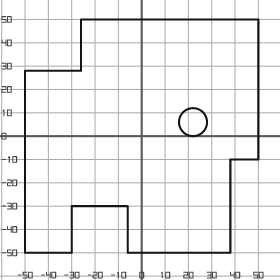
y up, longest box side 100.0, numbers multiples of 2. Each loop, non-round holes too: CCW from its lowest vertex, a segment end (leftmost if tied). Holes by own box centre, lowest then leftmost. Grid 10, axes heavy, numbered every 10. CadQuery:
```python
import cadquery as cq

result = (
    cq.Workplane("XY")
    .moveTo(-50.0, -50.0)
    .lineTo(-30.0, -50.0)
    .lineTo(-30.0, -30.0)
    .lineTo(-6.0, -30.0)
    .lineTo(-6.0, -50.0)
    .lineTo(38.0, -50.0)
    .lineTo(38.0, -10.0)
    .lineTo(50.0, -10.0)
    .lineTo(50.0, 50.0)
    .lineTo(-26.0, 50.0)
    .lineTo(-26.0, 28.0)
    .lineTo(-50.0, 28.0)
    .close()
    .moveTo(22.0, 6.0)
    .circle(6.0)
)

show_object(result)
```